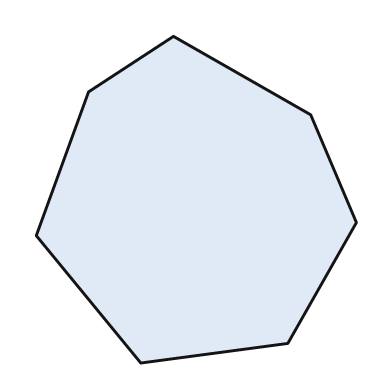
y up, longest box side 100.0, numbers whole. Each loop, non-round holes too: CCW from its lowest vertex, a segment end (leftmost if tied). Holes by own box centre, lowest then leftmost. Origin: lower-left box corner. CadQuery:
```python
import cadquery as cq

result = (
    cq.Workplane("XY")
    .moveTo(32.0, 0.0)
    .lineTo(77.0, 6.0)
    .lineTo(98.0, 43.0)
    .lineTo(84.0, 76.0)
    .lineTo(42.0, 100.0)
    .lineTo(16.0, 83.0)
    .lineTo(0.0, 39.0)
    .close()
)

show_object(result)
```